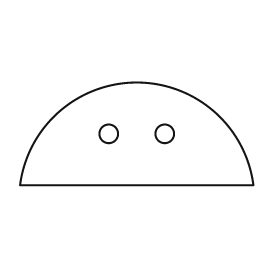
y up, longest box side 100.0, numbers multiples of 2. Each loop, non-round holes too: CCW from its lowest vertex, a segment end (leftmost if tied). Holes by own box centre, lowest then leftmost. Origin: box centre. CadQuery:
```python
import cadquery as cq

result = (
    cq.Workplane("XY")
    .moveTo(-50.0, -22.0)
    .lineTo(50.0, -22.0)
    .threePointArc((0.0, 22.0), (-50.0, -22.0))
    .close()
    .moveTo(-12.0, 0.0)
    .circle(4.0)
    .moveTo(12.0, 0.0)
    .circle(4.0)
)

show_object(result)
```